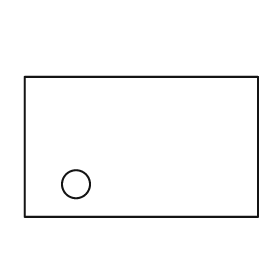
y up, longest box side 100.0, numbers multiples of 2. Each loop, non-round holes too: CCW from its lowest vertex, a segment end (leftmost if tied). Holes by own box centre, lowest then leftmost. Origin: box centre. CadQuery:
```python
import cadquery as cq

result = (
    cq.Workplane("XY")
    .moveTo(-50.0, -30.0)
    .lineTo(50.0, -30.0)
    .lineTo(50.0, 30.0)
    .lineTo(-50.0, 30.0)
    .close()
    .moveTo(-28.0, -16.0)
    .circle(6.0)
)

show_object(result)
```